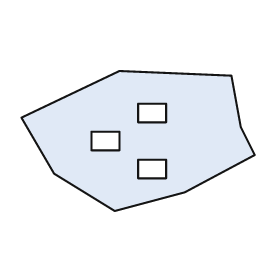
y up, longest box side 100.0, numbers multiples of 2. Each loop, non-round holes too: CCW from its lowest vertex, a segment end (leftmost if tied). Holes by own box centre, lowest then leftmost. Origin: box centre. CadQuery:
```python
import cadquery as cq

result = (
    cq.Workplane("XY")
    .moveTo(-10.0, -30.0)
    .lineTo(20.0, -22.0)
    .lineTo(50.0, -6.0)
    .lineTo(44.0, 6.0)
    .lineTo(40.0, 28.0)
    .lineTo(-8.0, 30.0)
    .lineTo(-50.0, 10.0)
    .lineTo(-36.0, -14.0)
    .close()
    .moveTo(0.0, -16.0)
    .lineTo(12.0, -16.0)
    .lineTo(12.0, -8.0)
    .lineTo(0.0, -8.0)
    .close()
    .moveTo(-20.0, -4.0)
    .lineTo(-8.0, -4.0)
    .lineTo(-8.0, 4.0)
    .lineTo(-20.0, 4.0)
    .close()
    .moveTo(0.0, 8.0)
    .lineTo(12.0, 8.0)
    .lineTo(12.0, 16.0)
    .lineTo(0.0, 16.0)
    .close()
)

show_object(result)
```